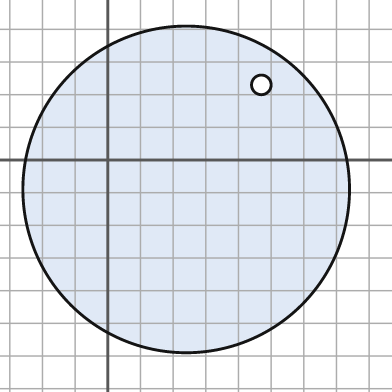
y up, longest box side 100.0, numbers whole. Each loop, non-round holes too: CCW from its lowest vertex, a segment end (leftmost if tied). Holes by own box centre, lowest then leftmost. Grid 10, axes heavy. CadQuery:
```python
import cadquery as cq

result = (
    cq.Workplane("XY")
    .moveTo(24.0, -9.0)
    .circle(50.0)
    .moveTo(47.0, 23.0)
    .circle(3.0)
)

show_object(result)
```